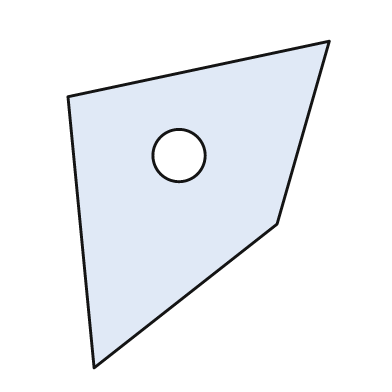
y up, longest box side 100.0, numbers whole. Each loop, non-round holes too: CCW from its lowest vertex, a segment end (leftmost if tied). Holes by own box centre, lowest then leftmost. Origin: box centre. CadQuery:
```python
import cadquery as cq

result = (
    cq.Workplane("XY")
    .moveTo(-32.0, -50.0)
    .lineTo(24.0, -6.0)
    .lineTo(40.0, 50.0)
    .lineTo(-40.0, 33.0)
    .close()
    .moveTo(-6.0, 15.0)
    .circle(8.0)
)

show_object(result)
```